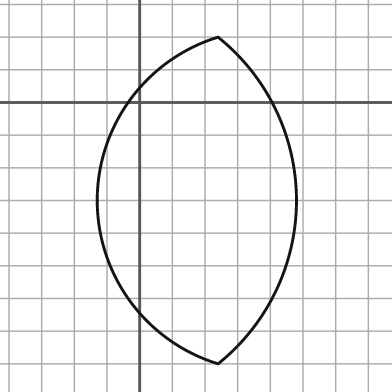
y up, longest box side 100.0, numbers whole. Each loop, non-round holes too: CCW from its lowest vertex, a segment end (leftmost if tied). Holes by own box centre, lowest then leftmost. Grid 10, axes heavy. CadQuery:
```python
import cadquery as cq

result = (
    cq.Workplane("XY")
    .moveTo(24.0, -80.0)
    .threePointArc((48.0, -30.0), (24.0, 20.0))
    .threePointArc((-13.0, -30.0), (24.0, -80.0))
    .close()
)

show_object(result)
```